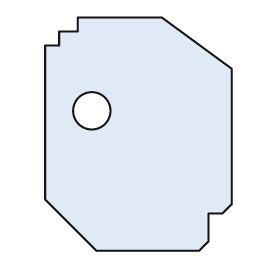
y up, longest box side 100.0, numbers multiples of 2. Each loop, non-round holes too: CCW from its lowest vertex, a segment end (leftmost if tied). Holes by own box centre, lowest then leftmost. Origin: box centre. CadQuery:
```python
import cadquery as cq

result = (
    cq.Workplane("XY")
    .moveTo(-18.0, -50.0)
    .lineTo(26.0, -50.0)
    .lineTo(30.0, -46.0)
    .lineTo(30.0, -34.0)
    .lineTo(36.0, -34.0)
    .lineTo(40.0, -30.0)
    .lineTo(40.0, 28.0)
    .lineTo(10.0, 50.0)
    .lineTo(-26.0, 50.0)
    .lineTo(-26.0, 44.0)
    .lineTo(-34.0, 44.0)
    .lineTo(-34.0, 38.0)
    .lineTo(-40.0, 38.0)
    .lineTo(-40.0, -28.0)
    .close()
    .moveTo(-20.0, 10.0)
    .circle(8.0)
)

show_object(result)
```